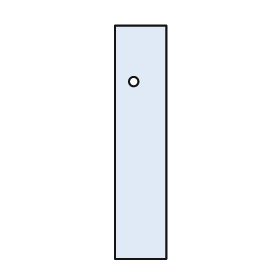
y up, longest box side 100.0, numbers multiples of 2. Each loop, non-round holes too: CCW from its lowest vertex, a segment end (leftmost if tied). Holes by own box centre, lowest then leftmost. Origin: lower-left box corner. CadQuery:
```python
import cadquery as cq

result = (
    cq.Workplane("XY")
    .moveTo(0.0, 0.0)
    .lineTo(22.0, 0.0)
    .lineTo(22.0, 100.0)
    .lineTo(0.0, 100.0)
    .close()
    .moveTo(8.0, 76.0)
    .circle(2.0)
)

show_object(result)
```